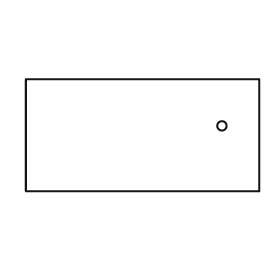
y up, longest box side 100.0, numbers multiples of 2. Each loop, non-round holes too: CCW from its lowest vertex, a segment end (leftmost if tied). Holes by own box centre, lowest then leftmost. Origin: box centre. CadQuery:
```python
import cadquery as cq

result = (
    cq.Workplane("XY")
    .moveTo(-50.0, -24.0)
    .lineTo(50.0, -24.0)
    .lineTo(50.0, 24.0)
    .lineTo(-50.0, 24.0)
    .close()
    .moveTo(34.0, 4.0)
    .circle(2.0)
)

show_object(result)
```